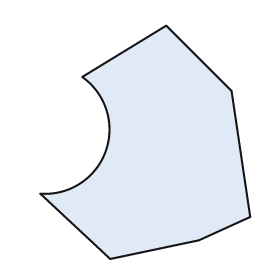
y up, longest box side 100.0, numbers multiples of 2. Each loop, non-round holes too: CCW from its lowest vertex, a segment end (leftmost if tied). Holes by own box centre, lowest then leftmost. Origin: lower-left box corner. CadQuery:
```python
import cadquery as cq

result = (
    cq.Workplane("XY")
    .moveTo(30.0, 0.0)
    .lineTo(68.0, 8.0)
    .lineTo(90.0, 18.0)
    .lineTo(82.0, 72.0)
    .lineTo(54.0, 100.0)
    .lineTo(18.0, 78.0)
    .threePointArc((28.0, 46.0), (0.0, 28.0))
    .close()
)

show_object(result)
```